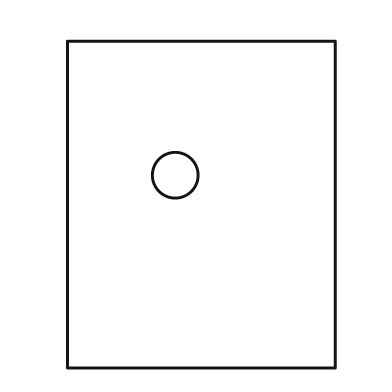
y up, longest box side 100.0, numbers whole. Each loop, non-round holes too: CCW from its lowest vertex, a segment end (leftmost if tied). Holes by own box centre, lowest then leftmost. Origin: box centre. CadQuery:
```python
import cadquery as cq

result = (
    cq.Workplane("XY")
    .moveTo(-41.0, -50.0)
    .lineTo(41.0, -50.0)
    .lineTo(41.0, 50.0)
    .lineTo(-41.0, 50.0)
    .close()
    .moveTo(-8.0, 9.0)
    .circle(7.0)
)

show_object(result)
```